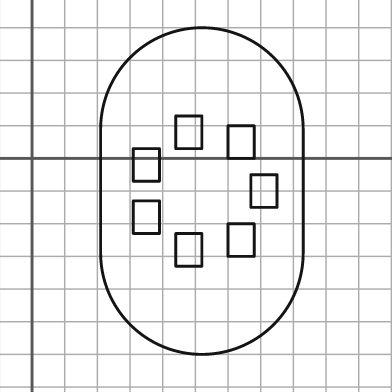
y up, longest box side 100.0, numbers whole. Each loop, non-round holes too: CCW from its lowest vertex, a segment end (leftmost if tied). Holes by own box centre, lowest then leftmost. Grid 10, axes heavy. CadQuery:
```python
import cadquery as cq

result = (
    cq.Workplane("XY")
    .moveTo(21.0, -29.0)
    .threePointArc((52.0, -60.0), (83.0, -29.0))
    .lineTo(83.0, 9.0)
    .threePointArc((52.0, 40.0), (21.0, 9.0))
    .close()
    .moveTo(44.0, -33.0)
    .lineTo(52.0, -33.0)
    .lineTo(52.0, -23.0)
    .lineTo(44.0, -23.0)
    .close()
    .moveTo(60.0, -30.0)
    .lineTo(68.0, -30.0)
    .lineTo(68.0, -20.0)
    .lineTo(60.0, -20.0)
    .close()
    .moveTo(31.0, -23.0)
    .lineTo(39.0, -23.0)
    .lineTo(39.0, -13.0)
    .lineTo(31.0, -13.0)
    .close()
    .moveTo(67.0, -15.0)
    .lineTo(75.0, -15.0)
    .lineTo(75.0, -5.0)
    .lineTo(67.0, -5.0)
    .close()
    .moveTo(31.0, -7.0)
    .lineTo(39.0, -7.0)
    .lineTo(39.0, 3.0)
    .lineTo(31.0, 3.0)
    .close()
    .moveTo(60.0, 0.0)
    .lineTo(68.0, 0.0)
    .lineTo(68.0, 10.0)
    .lineTo(60.0, 10.0)
    .close()
    .moveTo(44.0, 3.0)
    .lineTo(52.0, 3.0)
    .lineTo(52.0, 13.0)
    .lineTo(44.0, 13.0)
    .close()
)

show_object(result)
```